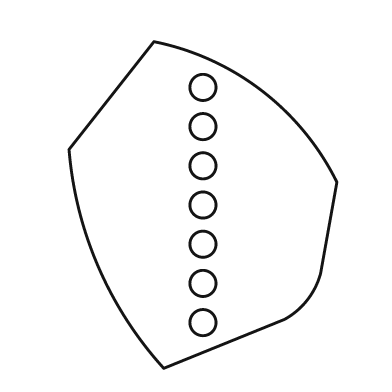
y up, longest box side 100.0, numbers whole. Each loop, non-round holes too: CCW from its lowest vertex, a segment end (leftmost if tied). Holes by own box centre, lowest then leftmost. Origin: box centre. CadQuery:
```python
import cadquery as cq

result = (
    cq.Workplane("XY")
    .moveTo(-12.0, -50.0)
    .lineTo(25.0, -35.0)
    .threePointArc((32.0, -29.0), (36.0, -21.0))
    .lineTo(41.0, 7.0)
    .threePointArc((18.0, 35.0), (-15.0, 50.0))
    .lineTo(-41.0, 17.0)
    .threePointArc((-32.0, -19.0), (-12.0, -50.0))
    .close()
    .moveTo(0.0, -36.0)
    .circle(4.0)
    .moveTo(0.0, -24.0)
    .circle(4.0)
    .moveTo(0.0, -12.0)
    .circle(4.0)
    .moveTo(0.0, 0.0)
    .circle(4.0)
    .moveTo(0.0, 12.0)
    .circle(4.0)
    .moveTo(0.0, 24.0)
    .circle(4.0)
    .moveTo(0.0, 36.0)
    .circle(4.0)
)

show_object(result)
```